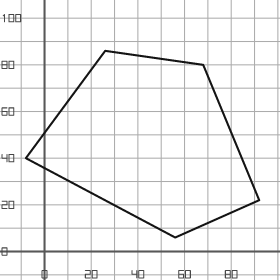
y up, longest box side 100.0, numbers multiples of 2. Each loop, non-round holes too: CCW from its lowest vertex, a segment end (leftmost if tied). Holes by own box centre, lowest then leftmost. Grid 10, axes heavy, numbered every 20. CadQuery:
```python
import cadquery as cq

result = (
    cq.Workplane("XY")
    .moveTo(56.0, 6.0)
    .lineTo(92.0, 22.0)
    .lineTo(68.0, 80.0)
    .lineTo(26.0, 86.0)
    .lineTo(-8.0, 40.0)
    .close()
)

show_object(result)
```